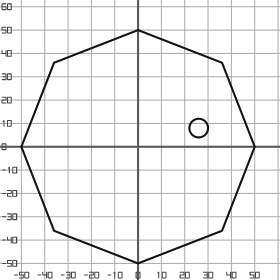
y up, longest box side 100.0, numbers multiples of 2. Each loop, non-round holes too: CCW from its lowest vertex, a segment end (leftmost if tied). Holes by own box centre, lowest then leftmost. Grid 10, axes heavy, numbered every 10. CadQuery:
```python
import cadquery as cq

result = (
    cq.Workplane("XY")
    .moveTo(0.0, -50.0)
    .lineTo(36.0, -36.0)
    .lineTo(50.0, 0.0)
    .lineTo(36.0, 36.0)
    .lineTo(0.0, 50.0)
    .lineTo(-36.0, 36.0)
    .lineTo(-50.0, 0.0)
    .lineTo(-36.0, -36.0)
    .close()
    .moveTo(26.0, 8.0)
    .circle(4.0)
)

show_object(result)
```